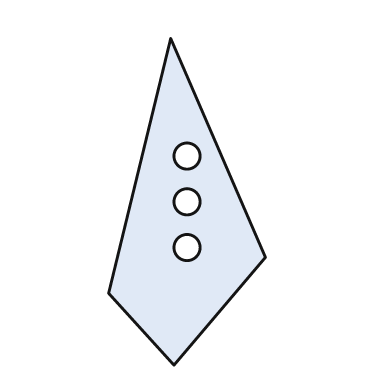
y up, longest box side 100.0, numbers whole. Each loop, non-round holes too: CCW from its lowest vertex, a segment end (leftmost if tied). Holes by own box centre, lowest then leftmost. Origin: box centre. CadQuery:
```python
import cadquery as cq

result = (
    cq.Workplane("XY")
    .moveTo(-4.0, -50.0)
    .lineTo(24.0, -17.0)
    .lineTo(-5.0, 50.0)
    .lineTo(-24.0, -28.0)
    .close()
    .moveTo(0.0, -14.0)
    .circle(4.0)
    .moveTo(0.0, 0.0)
    .circle(4.0)
    .moveTo(0.0, 14.0)
    .circle(4.0)
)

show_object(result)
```